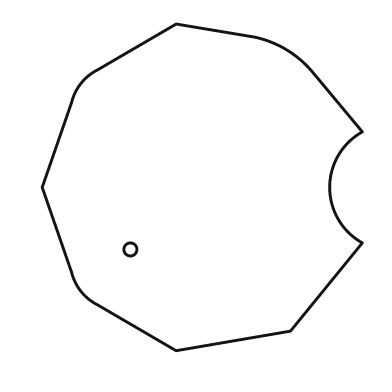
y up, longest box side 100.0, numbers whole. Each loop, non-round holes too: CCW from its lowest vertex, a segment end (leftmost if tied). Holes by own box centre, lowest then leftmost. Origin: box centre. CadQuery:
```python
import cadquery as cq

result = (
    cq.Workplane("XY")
    .moveTo(-8.0, -50.0)
    .lineTo(27.0, -44.0)
    .lineTo(49.0, -17.0)
    .threePointArc((39.0, 0.0), (49.0, 17.0))
    .lineTo(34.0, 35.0)
    .threePointArc((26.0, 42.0), (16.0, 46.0))
    .lineTo(-8.0, 50.0)
    .lineTo(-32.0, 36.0)
    .threePointArc((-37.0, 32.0), (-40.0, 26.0))
    .lineTo(-49.0, 0.0)
    .lineTo(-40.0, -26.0)
    .threePointArc((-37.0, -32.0), (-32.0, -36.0))
    .close()
    .moveTo(-22.0, -19.0)
    .circle(2.0)
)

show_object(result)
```